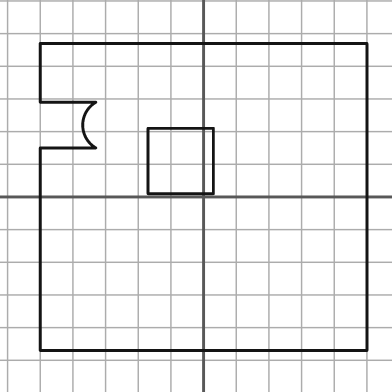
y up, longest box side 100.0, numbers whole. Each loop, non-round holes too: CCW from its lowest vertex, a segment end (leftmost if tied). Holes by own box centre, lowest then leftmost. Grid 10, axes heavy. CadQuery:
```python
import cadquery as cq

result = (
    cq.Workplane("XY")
    .moveTo(-50.0, -47.0)
    .lineTo(50.0, -47.0)
    .lineTo(50.0, 47.0)
    .lineTo(-50.0, 47.0)
    .lineTo(-50.0, 29.0)
    .lineTo(-33.0, 29.0)
    .threePointArc((-37.0, 22.0), (-33.0, 15.0))
    .lineTo(-50.0, 15.0)
    .close()
    .moveTo(-17.0, 1.0)
    .lineTo(3.0, 1.0)
    .lineTo(3.0, 21.0)
    .lineTo(-17.0, 21.0)
    .close()
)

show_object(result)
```